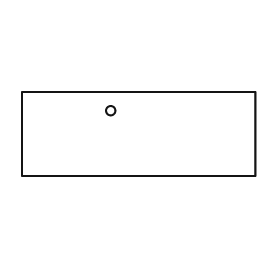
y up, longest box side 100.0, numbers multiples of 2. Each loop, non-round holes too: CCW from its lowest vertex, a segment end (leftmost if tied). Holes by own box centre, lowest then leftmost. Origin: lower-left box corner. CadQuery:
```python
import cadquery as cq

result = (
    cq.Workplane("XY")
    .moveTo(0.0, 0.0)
    .lineTo(100.0, 0.0)
    .lineTo(100.0, 36.0)
    .lineTo(0.0, 36.0)
    .close()
    .moveTo(38.0, 28.0)
    .circle(2.0)
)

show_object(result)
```